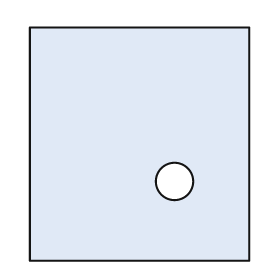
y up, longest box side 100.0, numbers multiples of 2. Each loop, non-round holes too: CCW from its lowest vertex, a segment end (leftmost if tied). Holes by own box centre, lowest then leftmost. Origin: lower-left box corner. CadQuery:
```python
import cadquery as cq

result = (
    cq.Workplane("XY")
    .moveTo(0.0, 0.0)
    .lineTo(94.0, 0.0)
    .lineTo(94.0, 100.0)
    .lineTo(0.0, 100.0)
    .close()
    .moveTo(62.0, 34.0)
    .circle(8.0)
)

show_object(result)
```